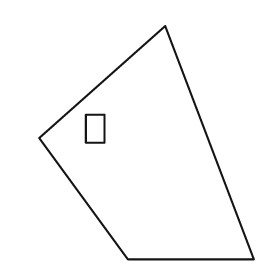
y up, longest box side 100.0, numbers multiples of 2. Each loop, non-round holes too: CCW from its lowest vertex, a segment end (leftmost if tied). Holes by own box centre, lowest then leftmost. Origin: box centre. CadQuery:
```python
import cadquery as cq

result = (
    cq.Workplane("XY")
    .moveTo(-8.0, -50.0)
    .lineTo(46.0, -50.0)
    .lineTo(8.0, 50.0)
    .lineTo(-46.0, 2.0)
    .close()
    .moveTo(-26.0, 0.0)
    .lineTo(-18.0, 0.0)
    .lineTo(-18.0, 12.0)
    .lineTo(-26.0, 12.0)
    .close()
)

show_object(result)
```